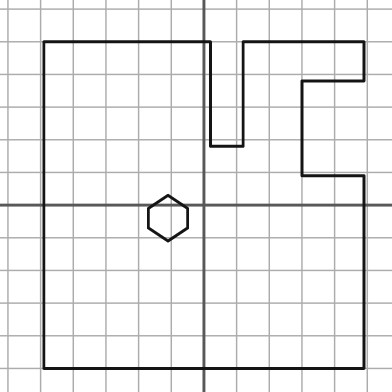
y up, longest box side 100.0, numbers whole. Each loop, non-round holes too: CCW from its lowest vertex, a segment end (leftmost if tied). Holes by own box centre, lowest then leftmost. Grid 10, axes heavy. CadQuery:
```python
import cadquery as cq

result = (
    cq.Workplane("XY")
    .moveTo(-49.0, -50.0)
    .lineTo(49.0, -50.0)
    .lineTo(49.0, 9.0)
    .lineTo(30.0, 9.0)
    .lineTo(30.0, 38.0)
    .lineTo(49.0, 38.0)
    .lineTo(49.0, 50.0)
    .lineTo(12.0, 50.0)
    .lineTo(12.0, 18.0)
    .lineTo(2.0, 18.0)
    .lineTo(2.0, 50.0)
    .lineTo(-49.0, 50.0)
    .close()
    .moveTo(-11.0, -11.0)
    .lineTo(-5.0, -7.0)
    .lineTo(-5.0, -1.0)
    .lineTo(-11.0, 3.0)
    .lineTo(-17.0, -1.0)
    .lineTo(-17.0, -7.0)
    .close()
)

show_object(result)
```